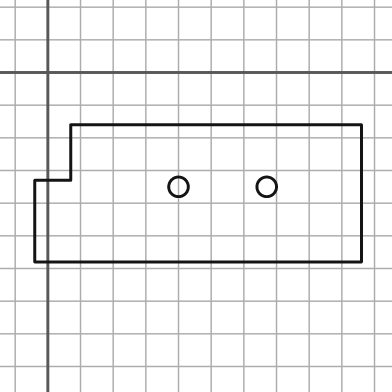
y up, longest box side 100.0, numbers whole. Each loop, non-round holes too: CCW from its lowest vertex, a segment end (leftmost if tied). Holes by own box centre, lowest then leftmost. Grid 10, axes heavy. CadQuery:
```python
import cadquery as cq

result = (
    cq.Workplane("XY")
    .moveTo(-4.0, -58.0)
    .lineTo(96.0, -58.0)
    .lineTo(96.0, -16.0)
    .lineTo(7.0, -16.0)
    .lineTo(7.0, -33.0)
    .lineTo(-4.0, -33.0)
    .close()
    .moveTo(40.0, -35.0)
    .circle(3.0)
    .moveTo(67.0, -35.0)
    .circle(3.0)
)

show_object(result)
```